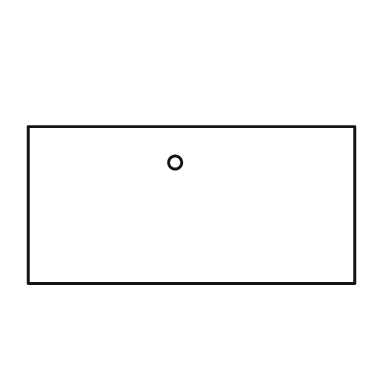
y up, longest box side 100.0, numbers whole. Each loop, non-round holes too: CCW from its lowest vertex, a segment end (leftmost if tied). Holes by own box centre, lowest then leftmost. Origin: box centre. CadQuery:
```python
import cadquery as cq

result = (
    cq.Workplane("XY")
    .moveTo(-50.0, -24.0)
    .lineTo(50.0, -24.0)
    .lineTo(50.0, 24.0)
    .lineTo(-50.0, 24.0)
    .close()
    .moveTo(-5.0, 13.0)
    .circle(2.0)
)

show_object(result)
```